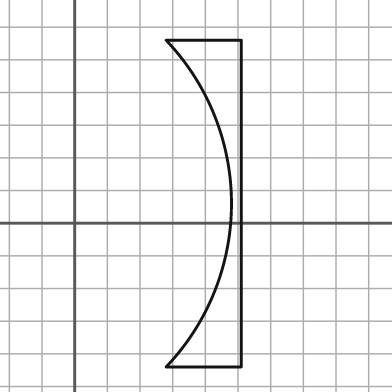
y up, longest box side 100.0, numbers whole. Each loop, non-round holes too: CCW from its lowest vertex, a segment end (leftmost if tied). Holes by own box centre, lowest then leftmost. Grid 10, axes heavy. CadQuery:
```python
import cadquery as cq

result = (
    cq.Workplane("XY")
    .moveTo(28.0, -44.0)
    .lineTo(51.0, -44.0)
    .lineTo(51.0, 56.0)
    .lineTo(28.0, 56.0)
    .threePointArc((48.0, 6.0), (28.0, -44.0))
    .close()
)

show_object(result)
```